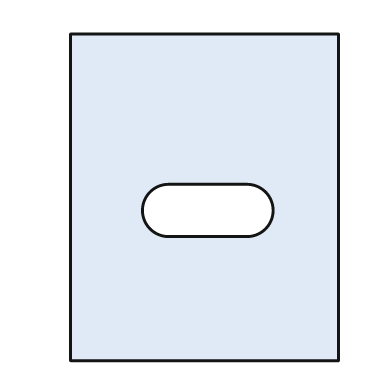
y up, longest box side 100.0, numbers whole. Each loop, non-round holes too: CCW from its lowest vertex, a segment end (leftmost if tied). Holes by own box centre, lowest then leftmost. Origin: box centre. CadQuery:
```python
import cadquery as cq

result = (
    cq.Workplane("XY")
    .moveTo(-41.0, -50.0)
    .lineTo(41.0, -50.0)
    .lineTo(41.0, 50.0)
    .lineTo(-41.0, 50.0)
    .close()
    .moveTo(-11.0, -12.0)
    .lineTo(13.0, -12.0)
    .threePointArc((21.0, -4.0), (13.0, 4.0))
    .lineTo(-11.0, 4.0)
    .threePointArc((-19.0, -4.0), (-11.0, -12.0))
    .close()
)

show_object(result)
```